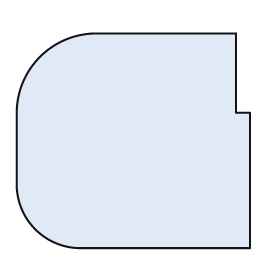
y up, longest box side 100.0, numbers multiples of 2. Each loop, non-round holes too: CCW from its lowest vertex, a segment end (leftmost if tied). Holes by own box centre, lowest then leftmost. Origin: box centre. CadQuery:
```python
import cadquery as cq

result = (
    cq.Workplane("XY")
    .moveTo(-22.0, -46.0)
    .lineTo(50.0, -46.0)
    .lineTo(50.0, 12.0)
    .lineTo(44.0, 12.0)
    .lineTo(44.0, 46.0)
    .lineTo(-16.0, 46.0)
    .threePointArc((-40.0, 36.0), (-50.0, 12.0))
    .lineTo(-50.0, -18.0)
    .threePointArc((-42.0, -38.0), (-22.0, -46.0))
    .close()
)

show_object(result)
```